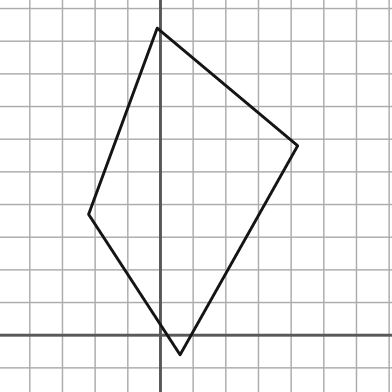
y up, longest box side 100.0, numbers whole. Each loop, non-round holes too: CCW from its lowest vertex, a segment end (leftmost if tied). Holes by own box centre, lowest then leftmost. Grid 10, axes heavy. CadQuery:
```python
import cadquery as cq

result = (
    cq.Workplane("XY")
    .moveTo(6.0, -6.0)
    .lineTo(42.0, 58.0)
    .lineTo(-1.0, 94.0)
    .lineTo(-22.0, 37.0)
    .close()
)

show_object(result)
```